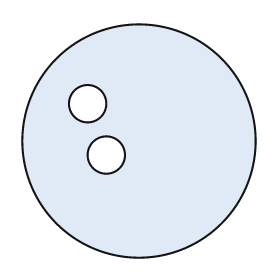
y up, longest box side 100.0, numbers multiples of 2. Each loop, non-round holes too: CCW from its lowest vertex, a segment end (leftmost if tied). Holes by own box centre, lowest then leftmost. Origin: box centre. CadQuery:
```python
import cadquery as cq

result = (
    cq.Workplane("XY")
    .moveTo(0.0, 0.0)
    .circle(50.0)
    .moveTo(-14.0, -6.0)
    .circle(8.0)
    .moveTo(-22.0, 16.0)
    .circle(8.0)
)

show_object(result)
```